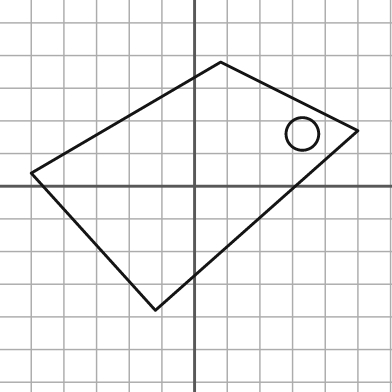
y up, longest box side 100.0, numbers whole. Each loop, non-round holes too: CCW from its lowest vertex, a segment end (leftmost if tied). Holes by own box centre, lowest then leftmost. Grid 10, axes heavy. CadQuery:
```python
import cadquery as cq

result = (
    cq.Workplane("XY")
    .moveTo(-12.0, -38.0)
    .lineTo(50.0, 17.0)
    .lineTo(8.0, 38.0)
    .lineTo(-50.0, 4.0)
    .close()
    .moveTo(33.0, 16.0)
    .circle(5.0)
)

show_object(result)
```